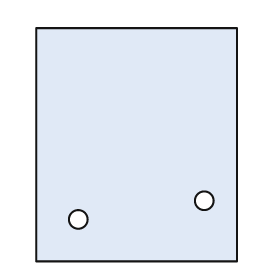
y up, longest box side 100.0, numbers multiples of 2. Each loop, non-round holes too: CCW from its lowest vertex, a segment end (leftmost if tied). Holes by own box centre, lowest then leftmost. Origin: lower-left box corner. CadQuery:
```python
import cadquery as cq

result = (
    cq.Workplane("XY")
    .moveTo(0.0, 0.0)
    .lineTo(86.0, 0.0)
    .lineTo(86.0, 100.0)
    .lineTo(0.0, 100.0)
    .close()
    .moveTo(18.0, 18.0)
    .circle(4.0)
    .moveTo(72.0, 26.0)
    .circle(4.0)
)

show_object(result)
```